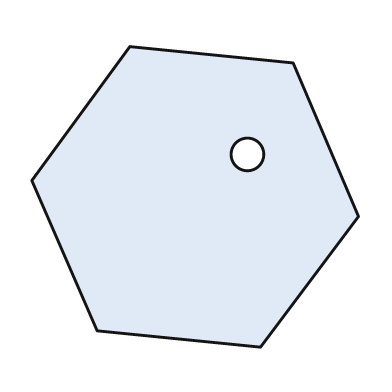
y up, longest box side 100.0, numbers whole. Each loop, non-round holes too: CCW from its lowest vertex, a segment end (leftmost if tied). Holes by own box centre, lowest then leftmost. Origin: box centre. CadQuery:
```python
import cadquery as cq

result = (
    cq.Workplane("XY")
    .moveTo(20.0, -46.0)
    .lineTo(50.0, -6.0)
    .lineTo(30.0, 41.0)
    .lineTo(-20.0, 46.0)
    .lineTo(-50.0, 5.0)
    .lineTo(-30.0, -41.0)
    .close()
    .moveTo(16.0, 13.0)
    .circle(5.0)
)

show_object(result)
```